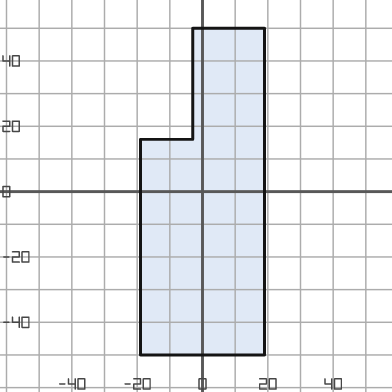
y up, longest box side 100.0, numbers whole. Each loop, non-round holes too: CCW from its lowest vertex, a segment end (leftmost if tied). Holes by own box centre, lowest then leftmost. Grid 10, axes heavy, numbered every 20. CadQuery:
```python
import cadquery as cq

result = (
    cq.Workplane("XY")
    .moveTo(-19.0, -50.0)
    .lineTo(19.0, -50.0)
    .lineTo(19.0, 50.0)
    .lineTo(-3.0, 50.0)
    .lineTo(-3.0, 16.0)
    .lineTo(-19.0, 16.0)
    .close()
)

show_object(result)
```